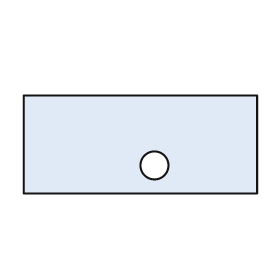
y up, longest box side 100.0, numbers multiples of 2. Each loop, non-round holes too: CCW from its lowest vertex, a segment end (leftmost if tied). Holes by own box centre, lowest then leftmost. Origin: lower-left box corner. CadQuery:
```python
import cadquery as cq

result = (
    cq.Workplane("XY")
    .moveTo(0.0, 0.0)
    .lineTo(100.0, 0.0)
    .lineTo(100.0, 42.0)
    .lineTo(0.0, 42.0)
    .close()
    .moveTo(56.0, 12.0)
    .circle(6.0)
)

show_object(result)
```